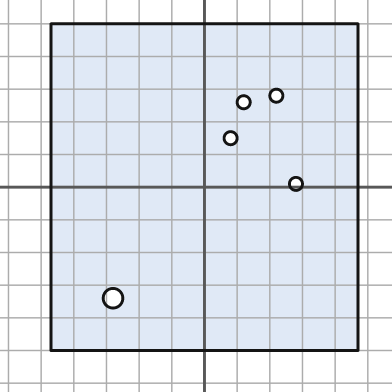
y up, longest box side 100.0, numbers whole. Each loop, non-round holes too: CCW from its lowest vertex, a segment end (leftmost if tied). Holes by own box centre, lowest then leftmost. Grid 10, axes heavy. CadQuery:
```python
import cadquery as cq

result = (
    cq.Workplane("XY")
    .moveTo(-47.0, -50.0)
    .lineTo(47.0, -50.0)
    .lineTo(47.0, 50.0)
    .lineTo(-47.0, 50.0)
    .close()
    .moveTo(-28.0, -34.0)
    .circle(3.0)
    .moveTo(28.0, 1.0)
    .circle(2.0)
    .moveTo(8.0, 15.0)
    .circle(2.0)
    .moveTo(12.0, 26.0)
    .circle(2.0)
    .moveTo(22.0, 28.0)
    .circle(2.0)
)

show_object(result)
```